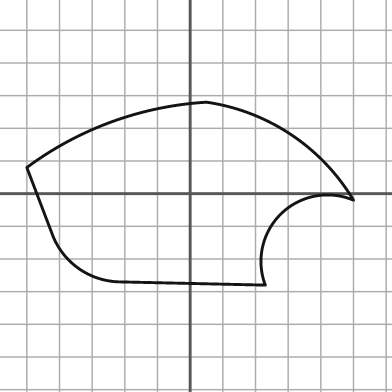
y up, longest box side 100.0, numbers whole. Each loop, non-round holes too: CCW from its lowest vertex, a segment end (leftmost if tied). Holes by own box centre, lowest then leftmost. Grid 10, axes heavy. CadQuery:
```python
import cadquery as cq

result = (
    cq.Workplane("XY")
    .moveTo(23.0, -28.0)
    .threePointArc((28.0, -6.0), (50.0, -2.0))
    .threePointArc((31.0, 18.0), (5.0, 28.0))
    .threePointArc((-24.0, 22.0), (-50.0, 8.0))
    .lineTo(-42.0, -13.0)
    .threePointArc((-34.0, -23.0), (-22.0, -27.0))
    .close()
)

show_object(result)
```